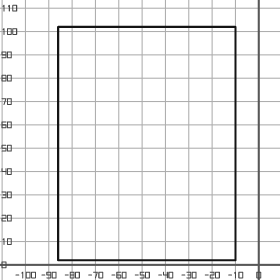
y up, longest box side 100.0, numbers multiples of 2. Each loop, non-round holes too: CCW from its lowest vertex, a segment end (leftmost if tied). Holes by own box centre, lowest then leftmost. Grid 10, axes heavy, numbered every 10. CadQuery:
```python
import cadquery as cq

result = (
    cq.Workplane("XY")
    .moveTo(-86.0, 2.0)
    .lineTo(-10.0, 2.0)
    .lineTo(-10.0, 102.0)
    .lineTo(-86.0, 102.0)
    .close()
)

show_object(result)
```